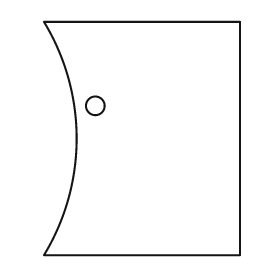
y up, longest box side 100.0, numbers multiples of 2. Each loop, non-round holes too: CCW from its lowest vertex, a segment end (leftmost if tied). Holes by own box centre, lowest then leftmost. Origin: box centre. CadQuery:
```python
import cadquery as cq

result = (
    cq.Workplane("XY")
    .moveTo(-42.0, -50.0)
    .lineTo(42.0, -50.0)
    .lineTo(42.0, 50.0)
    .lineTo(-42.0, 50.0)
    .threePointArc((-28.0, 0.0), (-42.0, -50.0))
    .close()
    .moveTo(-20.0, 14.0)
    .circle(4.0)
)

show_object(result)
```